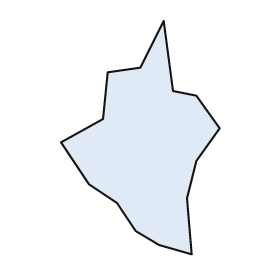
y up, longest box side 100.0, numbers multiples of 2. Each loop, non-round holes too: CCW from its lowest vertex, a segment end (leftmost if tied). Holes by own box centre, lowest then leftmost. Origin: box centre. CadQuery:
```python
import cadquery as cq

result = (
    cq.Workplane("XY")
    .moveTo(22.0, -50.0)
    .lineTo(20.0, -26.0)
    .lineTo(24.0, -10.0)
    .lineTo(34.0, 4.0)
    .lineTo(24.0, 18.0)
    .lineTo(14.0, 20.0)
    .lineTo(10.0, 50.0)
    .lineTo(0.0, 30.0)
    .lineTo(-14.0, 28.0)
    .lineTo(-16.0, 8.0)
    .lineTo(-34.0, -2.0)
    .lineTo(-22.0, -20.0)
    .lineTo(-10.0, -28.0)
    .lineTo(-2.0, -40.0)
    .lineTo(8.0, -46.0)
    .close()
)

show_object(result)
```